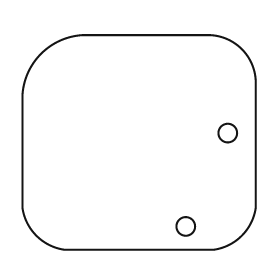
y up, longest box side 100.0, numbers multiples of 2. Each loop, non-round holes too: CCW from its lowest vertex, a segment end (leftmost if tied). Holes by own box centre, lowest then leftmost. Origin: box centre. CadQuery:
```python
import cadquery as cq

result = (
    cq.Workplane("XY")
    .moveTo(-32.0, -46.0)
    .lineTo(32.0, -46.0)
    .threePointArc((44.0, -40.0), (50.0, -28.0))
    .lineTo(50.0, 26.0)
    .threePointArc((44.0, 40.0), (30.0, 46.0))
    .lineTo(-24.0, 46.0)
    .threePointArc((-42.0, 38.0), (-50.0, 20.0))
    .lineTo(-50.0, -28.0)
    .threePointArc((-44.0, -40.0), (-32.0, -46.0))
    .close()
    .moveTo(20.0, -36.0)
    .circle(4.0)
    .moveTo(38.0, 4.0)
    .circle(4.0)
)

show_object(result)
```